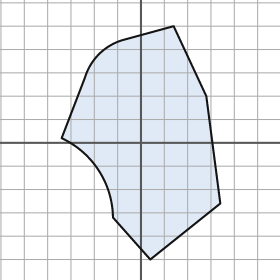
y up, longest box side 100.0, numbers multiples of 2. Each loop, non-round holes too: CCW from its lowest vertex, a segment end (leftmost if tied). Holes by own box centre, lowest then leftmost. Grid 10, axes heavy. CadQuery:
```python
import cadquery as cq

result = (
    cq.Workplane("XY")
    .moveTo(4.0, -50.0)
    .lineTo(34.0, -26.0)
    .lineTo(28.0, 20.0)
    .lineTo(14.0, 50.0)
    .lineTo(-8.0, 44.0)
    .threePointArc((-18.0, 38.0), (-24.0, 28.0))
    .lineTo(-34.0, 2.0)
    .threePointArc((-18.0, -12.0), (-12.0, -32.0))
    .close()
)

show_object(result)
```